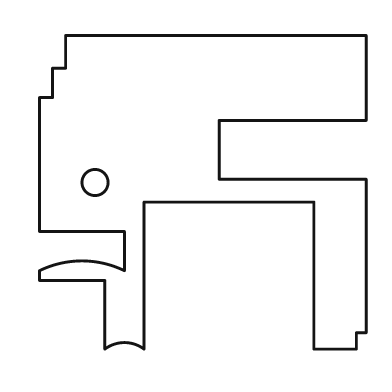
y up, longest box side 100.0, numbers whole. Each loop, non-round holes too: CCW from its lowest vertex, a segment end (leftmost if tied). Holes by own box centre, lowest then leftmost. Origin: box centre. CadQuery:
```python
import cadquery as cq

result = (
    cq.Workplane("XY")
    .moveTo(-30.0, -48.0)
    .threePointArc((-24.0, -46.0), (-18.0, -48.0))
    .lineTo(-18.0, -3.0)
    .lineTo(34.0, -3.0)
    .lineTo(34.0, -48.0)
    .lineTo(47.0, -48.0)
    .lineTo(47.0, -43.0)
    .lineTo(50.0, -43.0)
    .lineTo(50.0, 4.0)
    .lineTo(5.0, 4.0)
    .lineTo(5.0, 22.0)
    .lineTo(50.0, 22.0)
    .lineTo(50.0, 48.0)
    .lineTo(-42.0, 48.0)
    .lineTo(-42.0, 38.0)
    .lineTo(-46.0, 38.0)
    .lineTo(-46.0, 29.0)
    .lineTo(-50.0, 29.0)
    .lineTo(-50.0, -12.0)
    .lineTo(-24.0, -12.0)
    .lineTo(-24.0, -24.0)
    .threePointArc((-37.0, -21.0), (-50.0, -24.0))
    .lineTo(-50.0, -27.0)
    .lineTo(-30.0, -27.0)
    .close()
    .moveTo(-33.0, 3.0)
    .circle(4.0)
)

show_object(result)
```